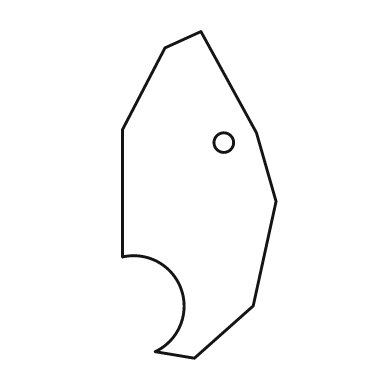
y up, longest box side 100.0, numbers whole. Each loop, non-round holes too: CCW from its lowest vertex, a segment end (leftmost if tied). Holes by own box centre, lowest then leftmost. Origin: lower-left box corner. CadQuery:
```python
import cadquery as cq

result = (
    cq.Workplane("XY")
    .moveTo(22.0, 0.0)
    .lineTo(40.0, 16.0)
    .lineTo(47.0, 48.0)
    .lineTo(41.0, 69.0)
    .lineTo(24.0, 100.0)
    .lineTo(13.0, 95.0)
    .lineTo(0.0, 70.0)
    .lineTo(0.0, 31.0)
    .threePointArc((18.0, 21.0), (10.0, 2.0))
    .close()
    .moveTo(31.0, 66.0)
    .circle(3.0)
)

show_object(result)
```